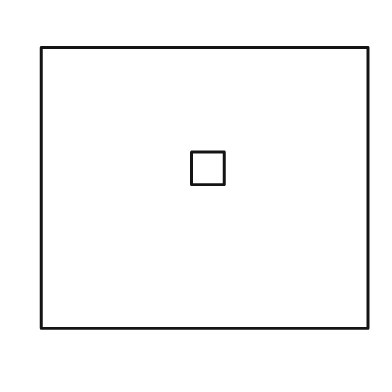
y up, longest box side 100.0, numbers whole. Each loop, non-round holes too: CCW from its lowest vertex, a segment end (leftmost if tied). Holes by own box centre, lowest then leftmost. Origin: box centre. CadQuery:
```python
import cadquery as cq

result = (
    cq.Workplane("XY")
    .moveTo(-50.0, -43.0)
    .lineTo(50.0, -43.0)
    .lineTo(50.0, 43.0)
    .lineTo(-50.0, 43.0)
    .close()
    .moveTo(-4.0, 1.0)
    .lineTo(6.0, 1.0)
    .lineTo(6.0, 11.0)
    .lineTo(-4.0, 11.0)
    .close()
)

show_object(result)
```